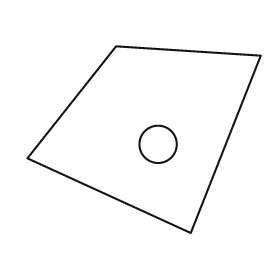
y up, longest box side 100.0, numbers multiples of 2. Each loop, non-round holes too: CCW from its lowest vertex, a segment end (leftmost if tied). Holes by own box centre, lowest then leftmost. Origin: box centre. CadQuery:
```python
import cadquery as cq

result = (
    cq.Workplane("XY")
    .moveTo(20.0, -40.0)
    .lineTo(50.0, 36.0)
    .lineTo(-12.0, 40.0)
    .lineTo(-50.0, -8.0)
    .close()
    .moveTo(6.0, -2.0)
    .circle(8.0)
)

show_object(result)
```